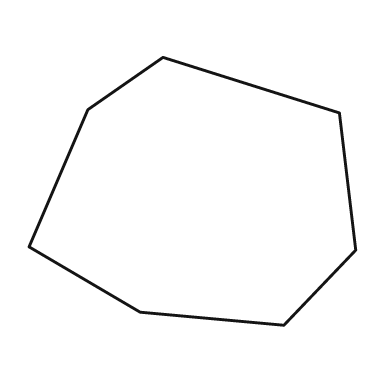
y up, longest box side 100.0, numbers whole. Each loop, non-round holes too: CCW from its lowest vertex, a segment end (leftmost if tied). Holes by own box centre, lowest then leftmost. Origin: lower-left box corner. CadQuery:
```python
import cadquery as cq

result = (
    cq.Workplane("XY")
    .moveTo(78.0, 0.0)
    .lineTo(100.0, 23.0)
    .lineTo(95.0, 65.0)
    .lineTo(41.0, 82.0)
    .lineTo(18.0, 66.0)
    .lineTo(0.0, 24.0)
    .lineTo(34.0, 4.0)
    .close()
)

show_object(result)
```